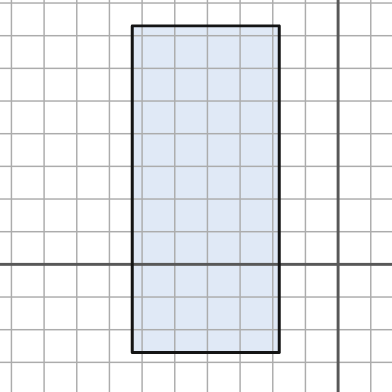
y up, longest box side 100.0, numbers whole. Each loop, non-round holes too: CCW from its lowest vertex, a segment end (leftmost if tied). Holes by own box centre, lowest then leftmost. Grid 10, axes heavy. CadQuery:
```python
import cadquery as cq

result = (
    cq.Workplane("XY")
    .moveTo(-63.0, -27.0)
    .lineTo(-18.0, -27.0)
    .lineTo(-18.0, 73.0)
    .lineTo(-63.0, 73.0)
    .close()
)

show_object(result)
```